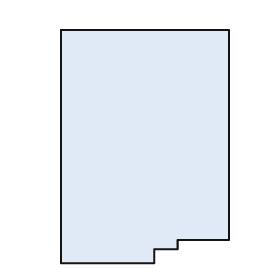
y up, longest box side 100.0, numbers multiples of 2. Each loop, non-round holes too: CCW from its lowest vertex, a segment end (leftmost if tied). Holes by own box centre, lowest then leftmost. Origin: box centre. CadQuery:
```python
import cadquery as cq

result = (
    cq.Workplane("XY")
    .moveTo(-36.0, -50.0)
    .lineTo(4.0, -50.0)
    .lineTo(4.0, -44.0)
    .lineTo(14.0, -44.0)
    .lineTo(14.0, -40.0)
    .lineTo(36.0, -40.0)
    .lineTo(36.0, 50.0)
    .lineTo(-36.0, 50.0)
    .close()
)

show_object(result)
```